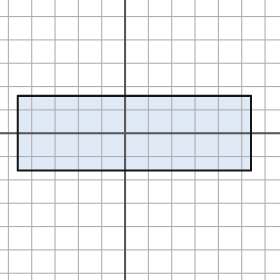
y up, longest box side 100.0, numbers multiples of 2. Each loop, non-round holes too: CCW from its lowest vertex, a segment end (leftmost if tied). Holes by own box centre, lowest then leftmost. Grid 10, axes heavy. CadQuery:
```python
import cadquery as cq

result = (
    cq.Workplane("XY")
    .moveTo(-46.0, -16.0)
    .lineTo(54.0, -16.0)
    .lineTo(54.0, 16.0)
    .lineTo(-46.0, 16.0)
    .close()
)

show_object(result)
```